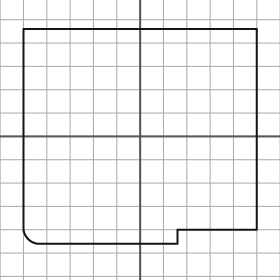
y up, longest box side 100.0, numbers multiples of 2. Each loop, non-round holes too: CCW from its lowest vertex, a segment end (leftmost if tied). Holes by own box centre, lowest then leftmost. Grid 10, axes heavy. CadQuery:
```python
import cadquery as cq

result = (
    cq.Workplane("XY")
    .moveTo(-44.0, -46.0)
    .lineTo(16.0, -46.0)
    .lineTo(16.0, -40.0)
    .lineTo(50.0, -40.0)
    .lineTo(50.0, 46.0)
    .lineTo(-50.0, 46.0)
    .lineTo(-50.0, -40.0)
    .threePointArc((-48.0, -44.0), (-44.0, -46.0))
    .close()
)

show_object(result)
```